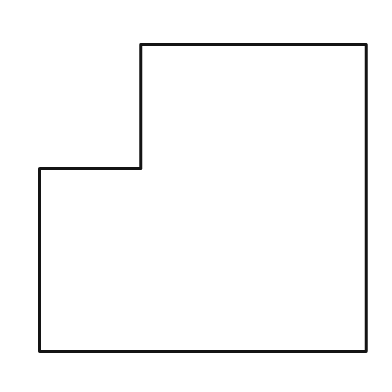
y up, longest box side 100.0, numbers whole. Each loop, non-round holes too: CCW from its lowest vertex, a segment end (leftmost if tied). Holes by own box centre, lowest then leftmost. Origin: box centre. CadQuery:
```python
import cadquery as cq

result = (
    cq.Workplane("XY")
    .moveTo(-50.0, -47.0)
    .lineTo(50.0, -47.0)
    .lineTo(50.0, 47.0)
    .lineTo(-19.0, 47.0)
    .lineTo(-19.0, 9.0)
    .lineTo(-50.0, 9.0)
    .close()
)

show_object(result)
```